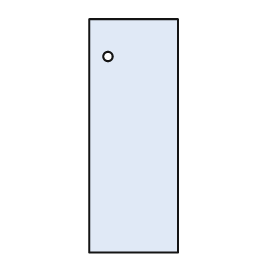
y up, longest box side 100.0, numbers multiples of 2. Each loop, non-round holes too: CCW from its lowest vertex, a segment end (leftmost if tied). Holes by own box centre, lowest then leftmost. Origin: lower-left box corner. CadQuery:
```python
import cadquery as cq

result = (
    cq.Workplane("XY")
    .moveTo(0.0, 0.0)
    .lineTo(38.0, 0.0)
    .lineTo(38.0, 100.0)
    .lineTo(0.0, 100.0)
    .close()
    .moveTo(8.0, 84.0)
    .circle(2.0)
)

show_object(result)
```